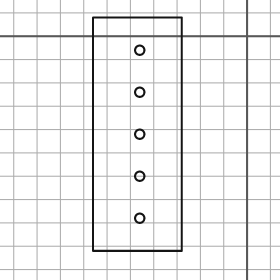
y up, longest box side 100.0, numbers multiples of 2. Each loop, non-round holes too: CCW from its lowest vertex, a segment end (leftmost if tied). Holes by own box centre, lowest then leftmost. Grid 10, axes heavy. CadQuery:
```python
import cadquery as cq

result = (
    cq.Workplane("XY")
    .moveTo(-66.0, -92.0)
    .lineTo(-28.0, -92.0)
    .lineTo(-28.0, 8.0)
    .lineTo(-66.0, 8.0)
    .close()
    .moveTo(-46.0, -78.0)
    .circle(2.0)
    .moveTo(-46.0, -60.0)
    .circle(2.0)
    .moveTo(-46.0, -42.0)
    .circle(2.0)
    .moveTo(-46.0, -24.0)
    .circle(2.0)
    .moveTo(-46.0, -6.0)
    .circle(2.0)
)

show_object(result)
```